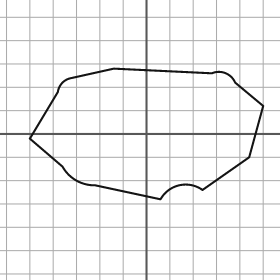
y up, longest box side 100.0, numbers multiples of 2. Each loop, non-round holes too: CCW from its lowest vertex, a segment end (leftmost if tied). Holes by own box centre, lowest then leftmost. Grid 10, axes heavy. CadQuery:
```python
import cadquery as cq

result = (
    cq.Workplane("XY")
    .moveTo(6.0, -28.0)
    .threePointArc((14.0, -22.0), (24.0, -24.0))
    .lineTo(44.0, -10.0)
    .lineTo(50.0, 12.0)
    .lineTo(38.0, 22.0)
    .threePointArc((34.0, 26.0), (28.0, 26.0))
    .lineTo(-14.0, 28.0)
    .lineTo(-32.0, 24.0)
    .threePointArc((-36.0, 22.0), (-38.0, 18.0))
    .lineTo(-50.0, -2.0)
    .lineTo(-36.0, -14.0)
    .threePointArc((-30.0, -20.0), (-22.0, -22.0))
    .close()
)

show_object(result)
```